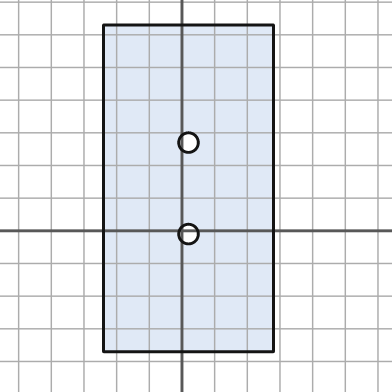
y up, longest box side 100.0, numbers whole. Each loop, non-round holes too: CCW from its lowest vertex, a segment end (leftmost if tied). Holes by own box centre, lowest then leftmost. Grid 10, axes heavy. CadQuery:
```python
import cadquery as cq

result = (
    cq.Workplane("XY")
    .moveTo(-24.0, -37.0)
    .lineTo(28.0, -37.0)
    .lineTo(28.0, 63.0)
    .lineTo(-24.0, 63.0)
    .close()
    .moveTo(2.0, -1.0)
    .circle(3.0)
    .moveTo(2.0, 27.0)
    .circle(3.0)
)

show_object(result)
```